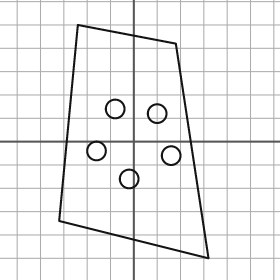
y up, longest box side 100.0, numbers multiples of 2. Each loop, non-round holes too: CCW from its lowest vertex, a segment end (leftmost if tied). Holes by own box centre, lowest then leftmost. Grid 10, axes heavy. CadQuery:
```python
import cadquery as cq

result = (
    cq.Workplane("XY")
    .moveTo(32.0, -50.0)
    .lineTo(18.0, 42.0)
    .lineTo(-24.0, 50.0)
    .lineTo(-32.0, -34.0)
    .close()
    .moveTo(-2.0, -16.0)
    .circle(4.0)
    .moveTo(16.0, -6.0)
    .circle(4.0)
    .moveTo(-16.0, -4.0)
    .circle(4.0)
    .moveTo(10.0, 12.0)
    .circle(4.0)
    .moveTo(-8.0, 14.0)
    .circle(4.0)
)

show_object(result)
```